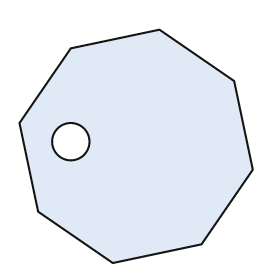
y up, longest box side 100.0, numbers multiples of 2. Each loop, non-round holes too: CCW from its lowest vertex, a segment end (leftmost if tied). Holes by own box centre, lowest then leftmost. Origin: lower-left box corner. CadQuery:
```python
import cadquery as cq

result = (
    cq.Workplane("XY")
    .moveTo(40.0, 0.0)
    .lineTo(78.0, 8.0)
    .lineTo(100.0, 40.0)
    .lineTo(92.0, 78.0)
    .lineTo(60.0, 100.0)
    .lineTo(22.0, 92.0)
    .lineTo(0.0, 60.0)
    .lineTo(8.0, 22.0)
    .close()
    .moveTo(22.0, 52.0)
    .circle(8.0)
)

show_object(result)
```